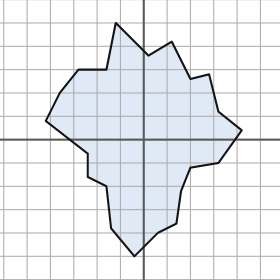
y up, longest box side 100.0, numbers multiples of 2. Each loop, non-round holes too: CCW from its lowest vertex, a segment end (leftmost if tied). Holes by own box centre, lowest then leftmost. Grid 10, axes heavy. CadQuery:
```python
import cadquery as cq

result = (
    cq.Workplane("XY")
    .moveTo(-4.0, -50.0)
    .lineTo(6.0, -40.0)
    .lineTo(14.0, -36.0)
    .lineTo(16.0, -22.0)
    .lineTo(20.0, -12.0)
    .lineTo(32.0, -10.0)
    .lineTo(42.0, 4.0)
    .lineTo(32.0, 12.0)
    .lineTo(28.0, 28.0)
    .lineTo(20.0, 26.0)
    .lineTo(12.0, 42.0)
    .lineTo(2.0, 36.0)
    .lineTo(-12.0, 50.0)
    .lineTo(-16.0, 30.0)
    .lineTo(-28.0, 30.0)
    .lineTo(-36.0, 20.0)
    .lineTo(-42.0, 8.0)
    .lineTo(-24.0, -6.0)
    .lineTo(-24.0, -16.0)
    .lineTo(-16.0, -20.0)
    .lineTo(-14.0, -38.0)
    .close()
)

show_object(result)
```